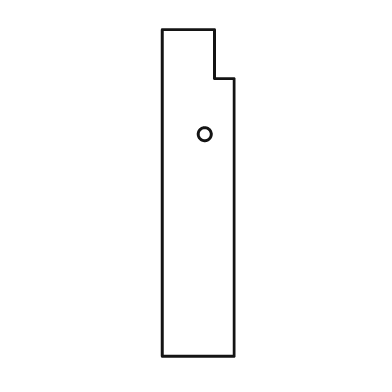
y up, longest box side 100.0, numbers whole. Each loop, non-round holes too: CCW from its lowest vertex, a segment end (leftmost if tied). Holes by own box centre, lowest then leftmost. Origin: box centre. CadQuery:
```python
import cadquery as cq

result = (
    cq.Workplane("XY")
    .moveTo(-11.0, -50.0)
    .lineTo(11.0, -50.0)
    .lineTo(11.0, 35.0)
    .lineTo(5.0, 35.0)
    .lineTo(5.0, 50.0)
    .lineTo(-11.0, 50.0)
    .close()
    .moveTo(2.0, 18.0)
    .circle(2.0)
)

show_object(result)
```